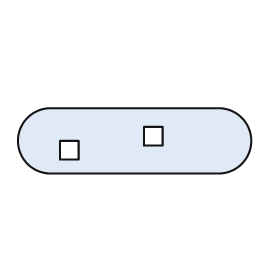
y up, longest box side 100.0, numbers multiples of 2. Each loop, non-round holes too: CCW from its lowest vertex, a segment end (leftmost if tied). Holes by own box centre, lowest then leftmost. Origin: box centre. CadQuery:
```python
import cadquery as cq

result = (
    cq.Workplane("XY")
    .moveTo(-36.0, -14.0)
    .lineTo(36.0, -14.0)
    .threePointArc((50.0, 0.0), (36.0, 14.0))
    .lineTo(-36.0, 14.0)
    .threePointArc((-50.0, 0.0), (-36.0, -14.0))
    .close()
    .moveTo(-32.0, -8.0)
    .lineTo(-24.0, -8.0)
    .lineTo(-24.0, 0.0)
    .lineTo(-32.0, 0.0)
    .close()
    .moveTo(4.0, -2.0)
    .lineTo(12.0, -2.0)
    .lineTo(12.0, 6.0)
    .lineTo(4.0, 6.0)
    .close()
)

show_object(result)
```